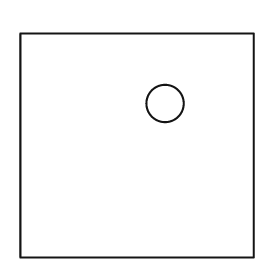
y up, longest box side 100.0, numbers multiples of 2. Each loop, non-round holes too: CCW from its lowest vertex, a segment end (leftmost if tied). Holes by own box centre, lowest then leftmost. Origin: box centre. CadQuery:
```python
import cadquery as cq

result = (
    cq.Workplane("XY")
    .moveTo(-50.0, -48.0)
    .lineTo(50.0, -48.0)
    .lineTo(50.0, 48.0)
    .lineTo(-50.0, 48.0)
    .close()
    .moveTo(12.0, 18.0)
    .circle(8.0)
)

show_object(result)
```